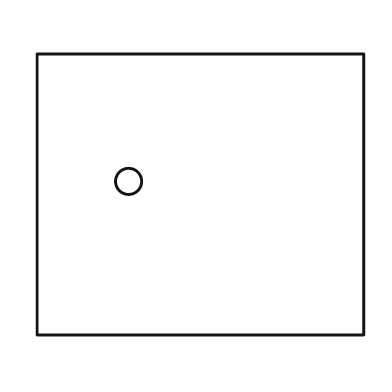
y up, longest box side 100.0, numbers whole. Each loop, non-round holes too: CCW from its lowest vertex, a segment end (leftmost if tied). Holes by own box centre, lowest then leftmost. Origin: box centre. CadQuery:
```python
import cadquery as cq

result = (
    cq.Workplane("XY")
    .moveTo(-50.0, -43.0)
    .lineTo(50.0, -43.0)
    .lineTo(50.0, 43.0)
    .lineTo(-50.0, 43.0)
    .close()
    .moveTo(-22.0, 4.0)
    .circle(4.0)
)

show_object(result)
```